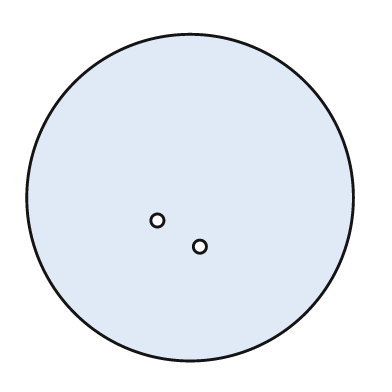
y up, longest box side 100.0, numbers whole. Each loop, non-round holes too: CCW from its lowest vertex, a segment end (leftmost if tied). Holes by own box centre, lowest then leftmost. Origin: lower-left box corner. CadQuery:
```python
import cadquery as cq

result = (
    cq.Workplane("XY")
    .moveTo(50.0, 50.0)
    .circle(50.0)
    .moveTo(53.0, 35.0)
    .circle(2.0)
    .moveTo(40.0, 43.0)
    .circle(2.0)
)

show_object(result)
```